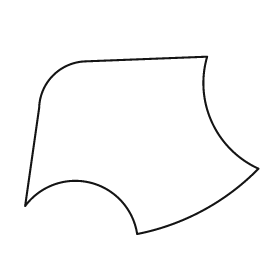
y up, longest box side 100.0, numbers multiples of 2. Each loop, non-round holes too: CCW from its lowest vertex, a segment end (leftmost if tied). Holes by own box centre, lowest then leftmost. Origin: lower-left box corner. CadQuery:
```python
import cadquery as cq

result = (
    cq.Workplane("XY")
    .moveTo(48.0, 0.0)
    .threePointArc((76.0, 10.0), (100.0, 28.0))
    .threePointArc((80.0, 48.0), (78.0, 76.0))
    .lineTo(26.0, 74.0)
    .threePointArc((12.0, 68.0), (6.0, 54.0))
    .lineTo(0.0, 12.0)
    .threePointArc((28.0, 22.0), (48.0, 0.0))
    .close()
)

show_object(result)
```